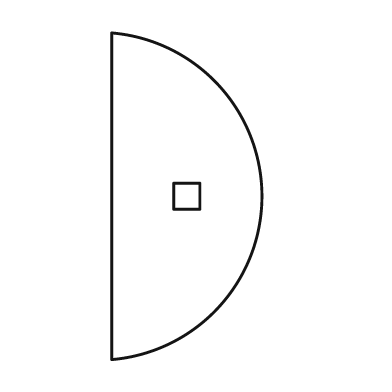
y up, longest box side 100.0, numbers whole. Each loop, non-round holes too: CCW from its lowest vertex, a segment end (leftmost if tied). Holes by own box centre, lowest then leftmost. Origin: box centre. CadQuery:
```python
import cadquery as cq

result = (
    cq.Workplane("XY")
    .moveTo(-23.0, -50.0)
    .threePointArc((23.0, 0.0), (-23.0, 50.0))
    .close()
    .moveTo(-4.0, -4.0)
    .lineTo(4.0, -4.0)
    .lineTo(4.0, 4.0)
    .lineTo(-4.0, 4.0)
    .close()
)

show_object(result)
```